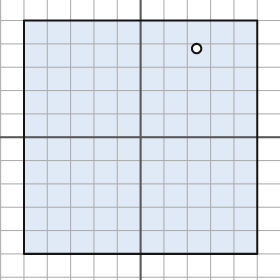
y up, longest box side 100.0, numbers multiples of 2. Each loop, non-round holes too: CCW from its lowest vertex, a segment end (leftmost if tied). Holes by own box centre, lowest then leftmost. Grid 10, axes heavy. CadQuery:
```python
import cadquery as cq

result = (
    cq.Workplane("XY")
    .moveTo(-50.0, -50.0)
    .lineTo(50.0, -50.0)
    .lineTo(50.0, 50.0)
    .lineTo(-50.0, 50.0)
    .close()
    .moveTo(24.0, 38.0)
    .circle(2.0)
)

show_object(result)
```